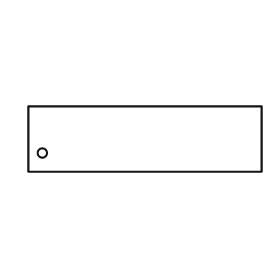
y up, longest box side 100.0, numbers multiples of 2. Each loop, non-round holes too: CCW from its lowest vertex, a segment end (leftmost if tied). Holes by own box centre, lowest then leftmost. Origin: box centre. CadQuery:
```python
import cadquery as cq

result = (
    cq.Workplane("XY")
    .moveTo(-50.0, -14.0)
    .lineTo(50.0, -14.0)
    .lineTo(50.0, 14.0)
    .lineTo(-50.0, 14.0)
    .close()
    .moveTo(-44.0, -6.0)
    .circle(2.0)
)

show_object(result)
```